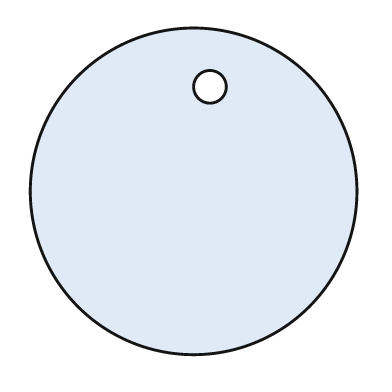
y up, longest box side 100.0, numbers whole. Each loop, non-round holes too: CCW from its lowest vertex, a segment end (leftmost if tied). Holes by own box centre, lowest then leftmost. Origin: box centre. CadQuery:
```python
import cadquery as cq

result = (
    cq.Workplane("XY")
    .moveTo(0.0, 0.0)
    .circle(50.0)
    .moveTo(5.0, 32.0)
    .circle(5.0)
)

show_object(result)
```